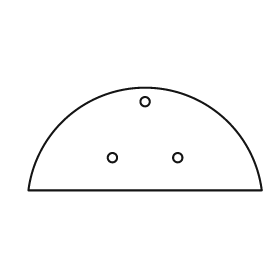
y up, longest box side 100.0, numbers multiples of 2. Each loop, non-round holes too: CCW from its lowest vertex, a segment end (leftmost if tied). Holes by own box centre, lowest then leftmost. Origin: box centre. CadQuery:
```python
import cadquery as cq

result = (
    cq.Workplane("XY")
    .moveTo(-50.0, -22.0)
    .lineTo(50.0, -22.0)
    .threePointArc((0.0, 22.0), (-50.0, -22.0))
    .close()
    .moveTo(-14.0, -8.0)
    .circle(2.0)
    .moveTo(14.0, -8.0)
    .circle(2.0)
    .moveTo(0.0, 16.0)
    .circle(2.0)
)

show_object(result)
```